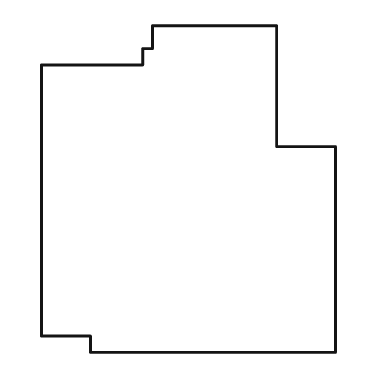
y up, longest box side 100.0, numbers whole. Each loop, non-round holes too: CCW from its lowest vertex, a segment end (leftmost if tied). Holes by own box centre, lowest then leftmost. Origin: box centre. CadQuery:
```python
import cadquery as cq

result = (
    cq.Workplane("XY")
    .moveTo(-30.0, -50.0)
    .lineTo(45.0, -50.0)
    .lineTo(45.0, 13.0)
    .lineTo(27.0, 13.0)
    .lineTo(27.0, 50.0)
    .lineTo(-11.0, 50.0)
    .lineTo(-11.0, 43.0)
    .lineTo(-14.0, 43.0)
    .lineTo(-14.0, 38.0)
    .lineTo(-45.0, 38.0)
    .lineTo(-45.0, -45.0)
    .lineTo(-30.0, -45.0)
    .close()
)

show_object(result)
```